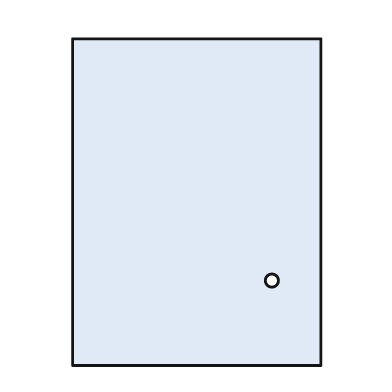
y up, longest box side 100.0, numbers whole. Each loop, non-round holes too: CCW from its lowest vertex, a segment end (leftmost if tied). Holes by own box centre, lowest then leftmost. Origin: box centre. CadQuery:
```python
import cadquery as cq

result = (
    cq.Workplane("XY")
    .moveTo(-38.0, -50.0)
    .lineTo(38.0, -50.0)
    .lineTo(38.0, 50.0)
    .lineTo(-38.0, 50.0)
    .close()
    .moveTo(23.0, -24.0)
    .circle(2.0)
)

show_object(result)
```